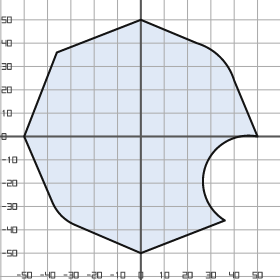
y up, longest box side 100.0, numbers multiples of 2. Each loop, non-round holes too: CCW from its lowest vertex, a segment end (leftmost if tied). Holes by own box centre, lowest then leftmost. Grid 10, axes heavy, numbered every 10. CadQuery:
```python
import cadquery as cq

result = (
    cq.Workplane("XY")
    .moveTo(0.0, -50.0)
    .lineTo(36.0, -36.0)
    .threePointArc((28.0, -12.0), (50.0, 0.0))
    .lineTo(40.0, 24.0)
    .threePointArc((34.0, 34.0), (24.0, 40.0))
    .lineTo(0.0, 50.0)
    .lineTo(-36.0, 36.0)
    .lineTo(-50.0, 0.0)
    .lineTo(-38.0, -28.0)
    .threePointArc((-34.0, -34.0), (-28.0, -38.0))
    .close()
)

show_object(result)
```